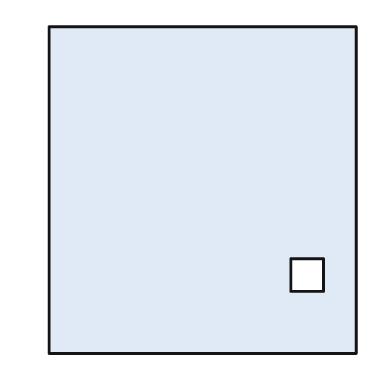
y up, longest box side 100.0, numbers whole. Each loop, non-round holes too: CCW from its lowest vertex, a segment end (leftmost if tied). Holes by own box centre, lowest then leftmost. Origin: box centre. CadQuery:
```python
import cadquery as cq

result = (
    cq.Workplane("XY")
    .moveTo(-47.0, -50.0)
    .lineTo(47.0, -50.0)
    .lineTo(47.0, 50.0)
    .lineTo(-47.0, 50.0)
    .close()
    .moveTo(27.0, -31.0)
    .lineTo(37.0, -31.0)
    .lineTo(37.0, -21.0)
    .lineTo(27.0, -21.0)
    .close()
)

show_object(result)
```